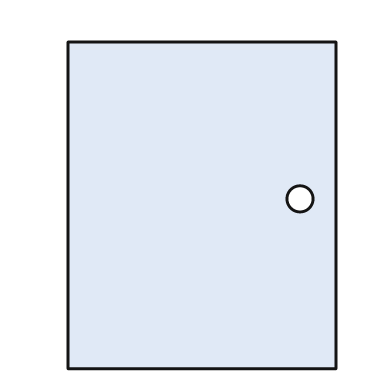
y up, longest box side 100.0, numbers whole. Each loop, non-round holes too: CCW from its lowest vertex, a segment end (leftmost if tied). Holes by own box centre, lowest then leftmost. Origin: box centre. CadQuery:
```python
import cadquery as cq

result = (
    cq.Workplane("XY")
    .moveTo(-41.0, -50.0)
    .lineTo(41.0, -50.0)
    .lineTo(41.0, 50.0)
    .lineTo(-41.0, 50.0)
    .close()
    .moveTo(30.0, 2.0)
    .circle(4.0)
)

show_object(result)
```